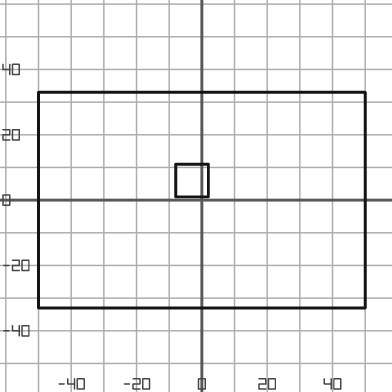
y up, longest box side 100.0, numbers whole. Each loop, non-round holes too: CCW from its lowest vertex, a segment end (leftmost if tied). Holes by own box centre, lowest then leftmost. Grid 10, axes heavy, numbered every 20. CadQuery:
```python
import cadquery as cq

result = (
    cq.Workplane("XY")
    .moveTo(-50.0, -33.0)
    .lineTo(50.0, -33.0)
    .lineTo(50.0, 33.0)
    .lineTo(-50.0, 33.0)
    .close()
    .moveTo(-8.0, 1.0)
    .lineTo(2.0, 1.0)
    .lineTo(2.0, 11.0)
    .lineTo(-8.0, 11.0)
    .close()
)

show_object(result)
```